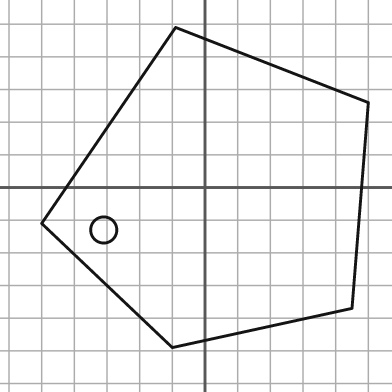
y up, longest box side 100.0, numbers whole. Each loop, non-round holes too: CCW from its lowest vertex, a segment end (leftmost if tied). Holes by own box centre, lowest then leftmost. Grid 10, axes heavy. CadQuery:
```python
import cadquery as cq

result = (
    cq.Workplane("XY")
    .moveTo(-10.0, -49.0)
    .lineTo(45.0, -37.0)
    .lineTo(50.0, 26.0)
    .lineTo(-9.0, 49.0)
    .lineTo(-50.0, -11.0)
    .close()
    .moveTo(-31.0, -13.0)
    .circle(4.0)
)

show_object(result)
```